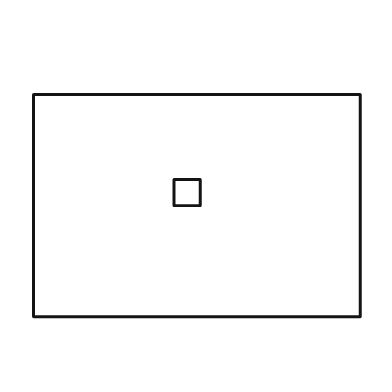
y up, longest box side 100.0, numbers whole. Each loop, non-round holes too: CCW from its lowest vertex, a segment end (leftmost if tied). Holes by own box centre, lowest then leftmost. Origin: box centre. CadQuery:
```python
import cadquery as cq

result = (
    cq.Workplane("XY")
    .moveTo(-50.0, -34.0)
    .lineTo(50.0, -34.0)
    .lineTo(50.0, 34.0)
    .lineTo(-50.0, 34.0)
    .close()
    .moveTo(-7.0, 0.0)
    .lineTo(1.0, 0.0)
    .lineTo(1.0, 8.0)
    .lineTo(-7.0, 8.0)
    .close()
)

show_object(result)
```